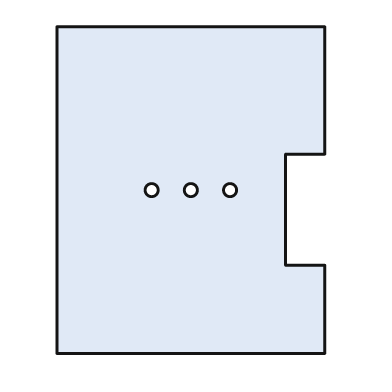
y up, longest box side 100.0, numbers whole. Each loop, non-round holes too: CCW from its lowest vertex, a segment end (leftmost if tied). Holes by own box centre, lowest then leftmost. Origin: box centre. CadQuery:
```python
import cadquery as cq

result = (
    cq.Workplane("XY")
    .moveTo(-41.0, -50.0)
    .lineTo(41.0, -50.0)
    .lineTo(41.0, -23.0)
    .lineTo(29.0, -23.0)
    .lineTo(29.0, 11.0)
    .lineTo(41.0, 11.0)
    .lineTo(41.0, 50.0)
    .lineTo(-41.0, 50.0)
    .close()
    .moveTo(-12.0, 0.0)
    .circle(2.0)
    .moveTo(0.0, 0.0)
    .circle(2.0)
    .moveTo(12.0, 0.0)
    .circle(2.0)
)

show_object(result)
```